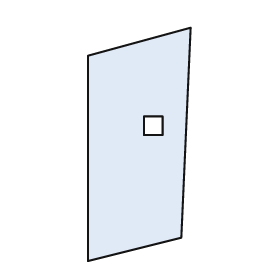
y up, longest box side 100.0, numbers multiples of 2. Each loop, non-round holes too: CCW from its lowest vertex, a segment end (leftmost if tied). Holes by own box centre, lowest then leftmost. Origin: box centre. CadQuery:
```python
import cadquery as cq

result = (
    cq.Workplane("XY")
    .moveTo(-22.0, -50.0)
    .lineTo(18.0, -40.0)
    .lineTo(22.0, 50.0)
    .lineTo(-22.0, 38.0)
    .close()
    .moveTo(2.0, 4.0)
    .lineTo(10.0, 4.0)
    .lineTo(10.0, 12.0)
    .lineTo(2.0, 12.0)
    .close()
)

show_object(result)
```